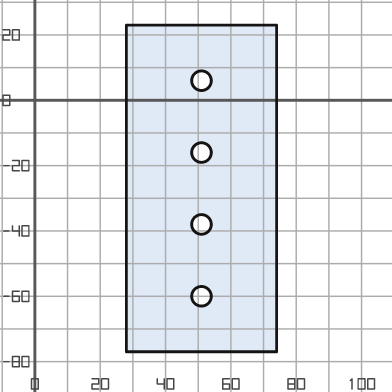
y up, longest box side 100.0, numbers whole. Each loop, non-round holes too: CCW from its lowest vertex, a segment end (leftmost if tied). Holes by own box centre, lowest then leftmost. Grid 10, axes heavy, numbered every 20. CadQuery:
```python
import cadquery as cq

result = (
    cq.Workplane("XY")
    .moveTo(28.0, -77.0)
    .lineTo(74.0, -77.0)
    .lineTo(74.0, 23.0)
    .lineTo(28.0, 23.0)
    .close()
    .moveTo(51.0, -60.0)
    .circle(3.0)
    .moveTo(51.0, -38.0)
    .circle(3.0)
    .moveTo(51.0, -16.0)
    .circle(3.0)
    .moveTo(51.0, 6.0)
    .circle(3.0)
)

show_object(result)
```